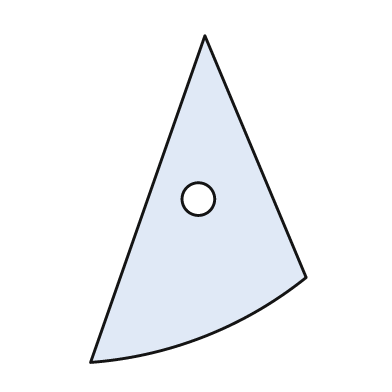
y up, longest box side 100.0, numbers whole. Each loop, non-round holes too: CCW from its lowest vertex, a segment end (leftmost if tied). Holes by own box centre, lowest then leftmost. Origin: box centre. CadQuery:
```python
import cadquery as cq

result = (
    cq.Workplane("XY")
    .moveTo(-33.0, -50.0)
    .threePointArc((2.0, -42.0), (33.0, -24.0))
    .lineTo(2.0, 50.0)
    .close()
    .moveTo(0.0, 0.0)
    .circle(5.0)
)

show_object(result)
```